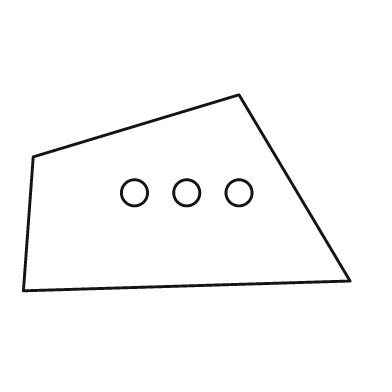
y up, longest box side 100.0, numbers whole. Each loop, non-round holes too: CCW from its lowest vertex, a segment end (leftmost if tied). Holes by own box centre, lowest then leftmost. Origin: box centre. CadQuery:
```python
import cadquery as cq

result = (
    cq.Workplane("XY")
    .moveTo(-50.0, -30.0)
    .lineTo(50.0, -27.0)
    .lineTo(16.0, 30.0)
    .lineTo(-47.0, 11.0)
    .close()
    .moveTo(-16.0, 0.0)
    .circle(4.0)
    .moveTo(0.0, 0.0)
    .circle(4.0)
    .moveTo(16.0, 0.0)
    .circle(4.0)
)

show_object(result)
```